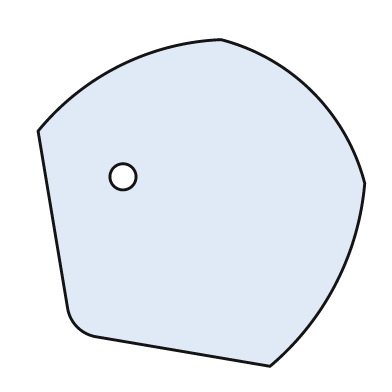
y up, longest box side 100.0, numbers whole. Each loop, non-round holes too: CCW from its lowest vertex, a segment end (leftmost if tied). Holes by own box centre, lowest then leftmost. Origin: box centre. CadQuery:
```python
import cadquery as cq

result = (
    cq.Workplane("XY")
    .moveTo(21.0, -50.0)
    .threePointArc((41.0, -25.0), (50.0, 6.0))
    .threePointArc((34.0, 34.0), (6.0, 50.0))
    .threePointArc((-25.0, 42.0), (-50.0, 22.0))
    .lineTo(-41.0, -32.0)
    .threePointArc((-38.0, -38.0), (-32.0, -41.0))
    .close()
    .moveTo(-24.0, 8.0)
    .circle(4.0)
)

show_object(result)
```